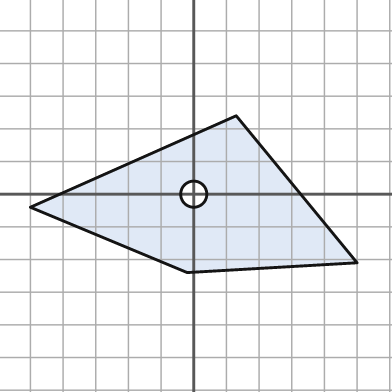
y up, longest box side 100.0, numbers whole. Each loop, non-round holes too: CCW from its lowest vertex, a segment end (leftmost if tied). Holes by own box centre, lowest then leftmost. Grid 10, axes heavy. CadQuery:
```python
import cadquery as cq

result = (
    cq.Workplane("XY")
    .moveTo(-2.0, -24.0)
    .lineTo(50.0, -21.0)
    .lineTo(13.0, 24.0)
    .lineTo(-50.0, -4.0)
    .close()
    .moveTo(0.0, 0.0)
    .circle(4.0)
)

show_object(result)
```